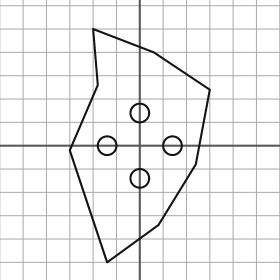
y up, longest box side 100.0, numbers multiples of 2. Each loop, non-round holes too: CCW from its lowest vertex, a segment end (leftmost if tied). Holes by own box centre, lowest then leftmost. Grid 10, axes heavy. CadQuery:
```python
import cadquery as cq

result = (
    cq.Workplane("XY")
    .moveTo(-14.0, -50.0)
    .lineTo(8.0, -34.0)
    .lineTo(24.0, -8.0)
    .lineTo(30.0, 24.0)
    .lineTo(6.0, 40.0)
    .lineTo(-20.0, 50.0)
    .lineTo(-18.0, 26.0)
    .lineTo(-30.0, -2.0)
    .close()
    .moveTo(0.0, -14.0)
    .circle(4.0)
    .moveTo(-14.0, 0.0)
    .circle(4.0)
    .moveTo(14.0, 0.0)
    .circle(4.0)
    .moveTo(0.0, 14.0)
    .circle(4.0)
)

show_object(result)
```